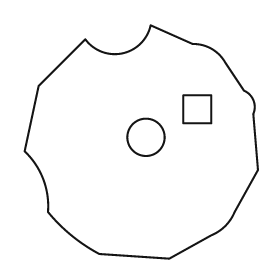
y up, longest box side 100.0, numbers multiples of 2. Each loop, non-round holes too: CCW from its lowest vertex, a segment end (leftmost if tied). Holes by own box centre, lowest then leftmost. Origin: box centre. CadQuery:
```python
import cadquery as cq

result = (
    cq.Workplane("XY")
    .moveTo(12.0, -50.0)
    .lineTo(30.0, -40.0)
    .threePointArc((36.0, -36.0), (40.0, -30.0))
    .lineTo(50.0, -12.0)
    .lineTo(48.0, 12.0)
    .threePointArc((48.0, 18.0), (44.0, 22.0))
    .lineTo(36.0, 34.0)
    .threePointArc((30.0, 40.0), (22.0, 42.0))
    .lineTo(4.0, 50.0)
    .threePointArc((-8.0, 38.0), (-24.0, 44.0))
    .lineTo(-44.0, 24.0)
    .lineTo(-50.0, -4.0)
    .threePointArc((-42.0, -16.0), (-40.0, -30.0))
    .threePointArc((-30.0, -40.0), (-18.0, -48.0))
    .close()
    .moveTo(2.0, 2.0)
    .circle(8.0)
    .moveTo(18.0, 8.0)
    .lineTo(30.0, 8.0)
    .lineTo(30.0, 20.0)
    .lineTo(18.0, 20.0)
    .close()
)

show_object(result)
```